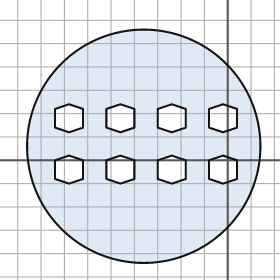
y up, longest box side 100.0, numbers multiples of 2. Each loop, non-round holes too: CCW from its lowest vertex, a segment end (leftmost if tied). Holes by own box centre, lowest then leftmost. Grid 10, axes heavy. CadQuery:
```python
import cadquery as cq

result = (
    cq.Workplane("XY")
    .moveTo(-36.0, 6.0)
    .circle(50.0)
    .moveTo(-68.0, -10.0)
    .lineTo(-62.0, -8.0)
    .lineTo(-62.0, 0.0)
    .lineTo(-68.0, 2.0)
    .lineTo(-74.0, 0.0)
    .lineTo(-74.0, -8.0)
    .close()
    .moveTo(-46.0, -10.0)
    .lineTo(-40.0, -8.0)
    .lineTo(-40.0, 0.0)
    .lineTo(-46.0, 2.0)
    .lineTo(-52.0, 0.0)
    .lineTo(-52.0, -8.0)
    .close()
    .moveTo(-24.0, -10.0)
    .lineTo(-18.0, -8.0)
    .lineTo(-18.0, 0.0)
    .lineTo(-24.0, 2.0)
    .lineTo(-30.0, 0.0)
    .lineTo(-30.0, -8.0)
    .close()
    .moveTo(-2.0, -10.0)
    .lineTo(4.0, -8.0)
    .lineTo(4.0, 0.0)
    .lineTo(-2.0, 2.0)
    .lineTo(-8.0, 0.0)
    .lineTo(-8.0, -8.0)
    .close()
    .moveTo(-68.0, 12.0)
    .lineTo(-62.0, 14.0)
    .lineTo(-62.0, 22.0)
    .lineTo(-68.0, 24.0)
    .lineTo(-74.0, 22.0)
    .lineTo(-74.0, 14.0)
    .close()
    .moveTo(-46.0, 12.0)
    .lineTo(-40.0, 14.0)
    .lineTo(-40.0, 22.0)
    .lineTo(-46.0, 24.0)
    .lineTo(-52.0, 22.0)
    .lineTo(-52.0, 14.0)
    .close()
    .moveTo(-24.0, 12.0)
    .lineTo(-18.0, 14.0)
    .lineTo(-18.0, 22.0)
    .lineTo(-24.0, 24.0)
    .lineTo(-30.0, 22.0)
    .lineTo(-30.0, 14.0)
    .close()
    .moveTo(-2.0, 12.0)
    .lineTo(4.0, 14.0)
    .lineTo(4.0, 22.0)
    .lineTo(-2.0, 24.0)
    .lineTo(-8.0, 22.0)
    .lineTo(-8.0, 14.0)
    .close()
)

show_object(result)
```